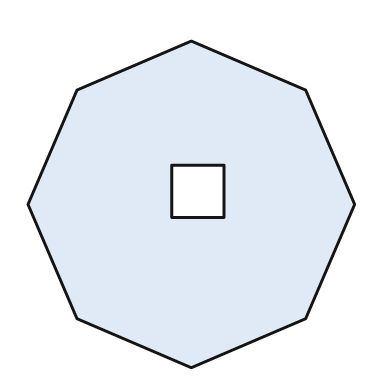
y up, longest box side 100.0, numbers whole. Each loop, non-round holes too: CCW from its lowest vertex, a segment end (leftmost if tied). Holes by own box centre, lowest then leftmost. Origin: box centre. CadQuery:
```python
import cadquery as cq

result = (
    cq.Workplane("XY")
    .moveTo(0.0, -50.0)
    .lineTo(35.0, -35.0)
    .lineTo(50.0, 0.0)
    .lineTo(35.0, 35.0)
    .lineTo(0.0, 50.0)
    .lineTo(-35.0, 35.0)
    .lineTo(-50.0, 0.0)
    .lineTo(-35.0, -35.0)
    .close()
    .moveTo(-6.0, -4.0)
    .lineTo(10.0, -4.0)
    .lineTo(10.0, 12.0)
    .lineTo(-6.0, 12.0)
    .close()
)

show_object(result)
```